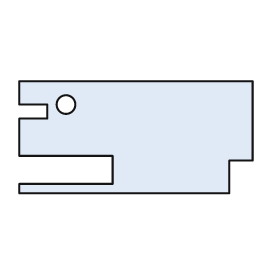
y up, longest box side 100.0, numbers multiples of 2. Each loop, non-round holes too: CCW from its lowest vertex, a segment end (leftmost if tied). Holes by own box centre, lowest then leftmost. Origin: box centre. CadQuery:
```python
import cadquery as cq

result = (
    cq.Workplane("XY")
    .moveTo(-50.0, -24.0)
    .lineTo(40.0, -24.0)
    .lineTo(40.0, -10.0)
    .lineTo(50.0, -10.0)
    .lineTo(50.0, 24.0)
    .lineTo(-50.0, 24.0)
    .lineTo(-50.0, 14.0)
    .lineTo(-38.0, 14.0)
    .lineTo(-38.0, 8.0)
    .lineTo(-50.0, 8.0)
    .lineTo(-50.0, -8.0)
    .lineTo(-10.0, -8.0)
    .lineTo(-10.0, -20.0)
    .lineTo(-50.0, -20.0)
    .close()
    .moveTo(-30.0, 14.0)
    .circle(4.0)
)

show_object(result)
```